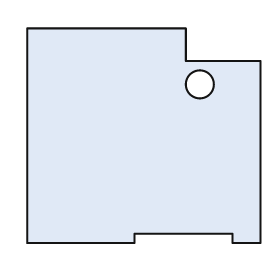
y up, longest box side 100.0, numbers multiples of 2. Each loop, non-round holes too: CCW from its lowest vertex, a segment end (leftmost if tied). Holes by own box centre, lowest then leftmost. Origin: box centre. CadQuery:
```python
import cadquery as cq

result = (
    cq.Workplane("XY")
    .moveTo(-50.0, -46.0)
    .lineTo(-4.0, -46.0)
    .lineTo(-4.0, -42.0)
    .lineTo(38.0, -42.0)
    .lineTo(38.0, -46.0)
    .lineTo(50.0, -46.0)
    .lineTo(50.0, 32.0)
    .lineTo(18.0, 32.0)
    .lineTo(18.0, 46.0)
    .lineTo(-50.0, 46.0)
    .close()
    .moveTo(24.0, 22.0)
    .circle(6.0)
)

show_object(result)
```